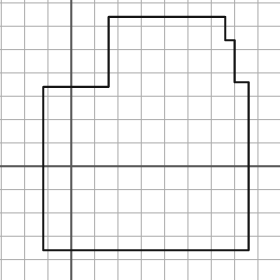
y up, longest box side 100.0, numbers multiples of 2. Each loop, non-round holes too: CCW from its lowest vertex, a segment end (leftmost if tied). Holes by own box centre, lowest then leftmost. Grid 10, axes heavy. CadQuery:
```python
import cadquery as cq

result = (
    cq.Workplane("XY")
    .moveTo(-12.0, -36.0)
    .lineTo(76.0, -36.0)
    .lineTo(76.0, 36.0)
    .lineTo(70.0, 36.0)
    .lineTo(70.0, 54.0)
    .lineTo(66.0, 54.0)
    .lineTo(66.0, 64.0)
    .lineTo(16.0, 64.0)
    .lineTo(16.0, 34.0)
    .lineTo(-12.0, 34.0)
    .close()
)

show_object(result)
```